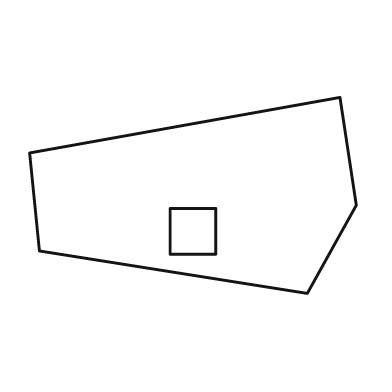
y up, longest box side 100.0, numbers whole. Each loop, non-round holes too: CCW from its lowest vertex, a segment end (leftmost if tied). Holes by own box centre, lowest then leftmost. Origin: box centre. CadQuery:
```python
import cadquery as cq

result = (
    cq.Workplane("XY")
    .moveTo(35.0, -30.0)
    .lineTo(50.0, -3.0)
    .lineTo(45.0, 30.0)
    .lineTo(-50.0, 13.0)
    .lineTo(-47.0, -17.0)
    .close()
    .moveTo(-7.0, -18.0)
    .lineTo(7.0, -18.0)
    .lineTo(7.0, -4.0)
    .lineTo(-7.0, -4.0)
    .close()
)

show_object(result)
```